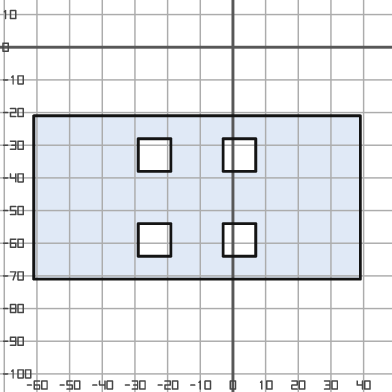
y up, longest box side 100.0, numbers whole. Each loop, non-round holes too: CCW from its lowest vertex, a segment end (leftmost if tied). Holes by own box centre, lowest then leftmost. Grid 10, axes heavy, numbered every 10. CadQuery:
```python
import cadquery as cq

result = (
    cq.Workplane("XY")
    .moveTo(-61.0, -71.0)
    .lineTo(39.0, -71.0)
    .lineTo(39.0, -21.0)
    .lineTo(-61.0, -21.0)
    .close()
    .moveTo(-29.0, -64.0)
    .lineTo(-19.0, -64.0)
    .lineTo(-19.0, -54.0)
    .lineTo(-29.0, -54.0)
    .close()
    .moveTo(-3.0, -64.0)
    .lineTo(7.0, -64.0)
    .lineTo(7.0, -54.0)
    .lineTo(-3.0, -54.0)
    .close()
    .moveTo(-29.0, -38.0)
    .lineTo(-19.0, -38.0)
    .lineTo(-19.0, -28.0)
    .lineTo(-29.0, -28.0)
    .close()
    .moveTo(-3.0, -38.0)
    .lineTo(7.0, -38.0)
    .lineTo(7.0, -28.0)
    .lineTo(-3.0, -28.0)
    .close()
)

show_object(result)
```